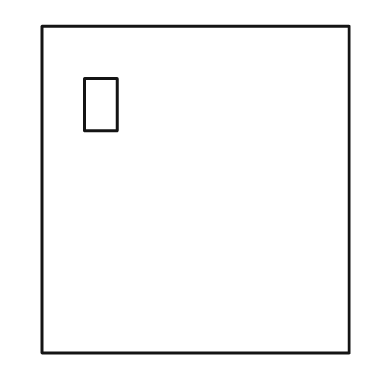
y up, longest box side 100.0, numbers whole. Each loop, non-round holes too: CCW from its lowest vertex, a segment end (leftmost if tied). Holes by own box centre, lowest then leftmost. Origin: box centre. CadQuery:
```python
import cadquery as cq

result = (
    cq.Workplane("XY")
    .moveTo(-47.0, -50.0)
    .lineTo(47.0, -50.0)
    .lineTo(47.0, 50.0)
    .lineTo(-47.0, 50.0)
    .close()
    .moveTo(-34.0, 18.0)
    .lineTo(-24.0, 18.0)
    .lineTo(-24.0, 34.0)
    .lineTo(-34.0, 34.0)
    .close()
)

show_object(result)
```